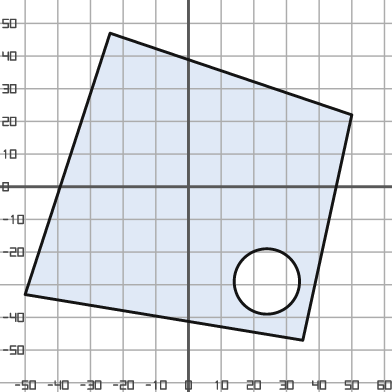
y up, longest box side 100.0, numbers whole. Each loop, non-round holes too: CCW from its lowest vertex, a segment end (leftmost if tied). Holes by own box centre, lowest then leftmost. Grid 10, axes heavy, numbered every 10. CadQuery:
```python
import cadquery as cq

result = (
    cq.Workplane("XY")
    .moveTo(35.0, -47.0)
    .lineTo(50.0, 22.0)
    .lineTo(-24.0, 47.0)
    .lineTo(-50.0, -33.0)
    .close()
    .moveTo(24.0, -29.0)
    .circle(10.0)
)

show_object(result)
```